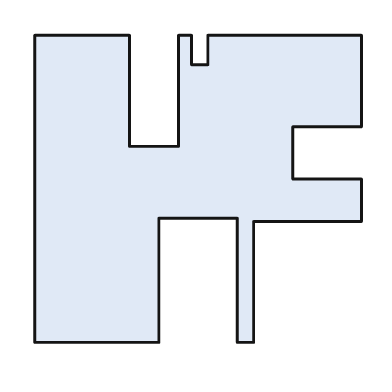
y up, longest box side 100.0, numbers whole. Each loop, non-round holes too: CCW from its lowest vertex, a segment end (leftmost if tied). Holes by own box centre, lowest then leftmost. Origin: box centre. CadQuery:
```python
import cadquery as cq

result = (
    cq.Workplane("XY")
    .moveTo(-50.0, -47.0)
    .lineTo(-12.0, -47.0)
    .lineTo(-12.0, -9.0)
    .lineTo(12.0, -9.0)
    .lineTo(12.0, -47.0)
    .lineTo(17.0, -47.0)
    .lineTo(17.0, -10.0)
    .lineTo(50.0, -10.0)
    .lineTo(50.0, 3.0)
    .lineTo(29.0, 3.0)
    .lineTo(29.0, 19.0)
    .lineTo(50.0, 19.0)
    .lineTo(50.0, 47.0)
    .lineTo(3.0, 47.0)
    .lineTo(3.0, 38.0)
    .lineTo(-2.0, 38.0)
    .lineTo(-2.0, 47.0)
    .lineTo(-6.0, 47.0)
    .lineTo(-6.0, 13.0)
    .lineTo(-21.0, 13.0)
    .lineTo(-21.0, 47.0)
    .lineTo(-50.0, 47.0)
    .close()
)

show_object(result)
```